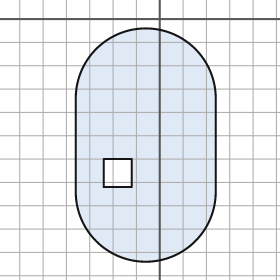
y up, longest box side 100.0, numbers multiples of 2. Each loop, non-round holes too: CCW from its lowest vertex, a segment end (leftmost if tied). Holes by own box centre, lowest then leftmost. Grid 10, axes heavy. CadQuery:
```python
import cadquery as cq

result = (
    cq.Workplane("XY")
    .moveTo(-36.0, -74.0)
    .threePointArc((-6.0, -104.0), (24.0, -74.0))
    .lineTo(24.0, -34.0)
    .threePointArc((-6.0, -4.0), (-36.0, -34.0))
    .close()
    .moveTo(-24.0, -72.0)
    .lineTo(-12.0, -72.0)
    .lineTo(-12.0, -60.0)
    .lineTo(-24.0, -60.0)
    .close()
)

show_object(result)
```